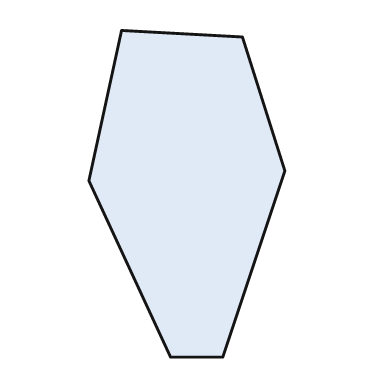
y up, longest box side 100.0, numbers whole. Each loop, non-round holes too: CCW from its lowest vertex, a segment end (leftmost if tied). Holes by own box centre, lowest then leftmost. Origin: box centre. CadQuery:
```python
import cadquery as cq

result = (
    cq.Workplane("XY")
    .moveTo(-5.0, -50.0)
    .lineTo(11.0, -50.0)
    .lineTo(30.0, 7.0)
    .lineTo(17.0, 48.0)
    .lineTo(-20.0, 50.0)
    .lineTo(-30.0, 4.0)
    .close()
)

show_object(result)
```